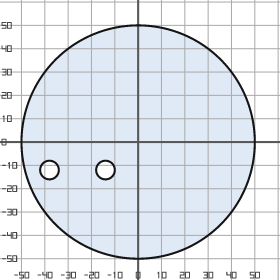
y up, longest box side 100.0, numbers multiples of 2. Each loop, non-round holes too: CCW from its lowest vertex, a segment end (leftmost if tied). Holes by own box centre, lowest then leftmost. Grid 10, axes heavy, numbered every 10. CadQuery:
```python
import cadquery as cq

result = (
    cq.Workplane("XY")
    .moveTo(0.0, 0.0)
    .circle(50.0)
    .moveTo(-38.0, -12.0)
    .circle(4.0)
    .moveTo(-14.0, -12.0)
    .circle(4.0)
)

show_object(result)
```